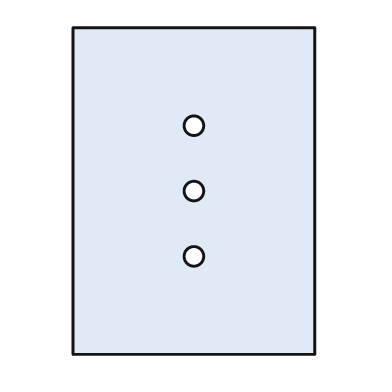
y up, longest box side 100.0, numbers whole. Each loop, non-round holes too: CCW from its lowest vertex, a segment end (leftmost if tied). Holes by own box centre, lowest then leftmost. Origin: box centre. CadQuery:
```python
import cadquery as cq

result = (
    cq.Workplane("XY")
    .moveTo(-37.0, -50.0)
    .lineTo(37.0, -50.0)
    .lineTo(37.0, 50.0)
    .lineTo(-37.0, 50.0)
    .close()
    .moveTo(0.0, -20.0)
    .circle(3.0)
    .moveTo(0.0, 0.0)
    .circle(3.0)
    .moveTo(0.0, 20.0)
    .circle(3.0)
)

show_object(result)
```